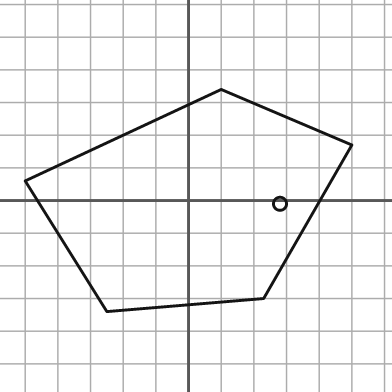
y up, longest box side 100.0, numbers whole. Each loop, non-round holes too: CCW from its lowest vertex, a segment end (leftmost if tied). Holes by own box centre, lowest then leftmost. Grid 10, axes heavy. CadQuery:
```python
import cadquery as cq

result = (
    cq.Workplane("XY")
    .moveTo(-25.0, -34.0)
    .lineTo(23.0, -30.0)
    .lineTo(50.0, 17.0)
    .lineTo(10.0, 34.0)
    .lineTo(-50.0, 6.0)
    .close()
    .moveTo(28.0, -1.0)
    .circle(2.0)
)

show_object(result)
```